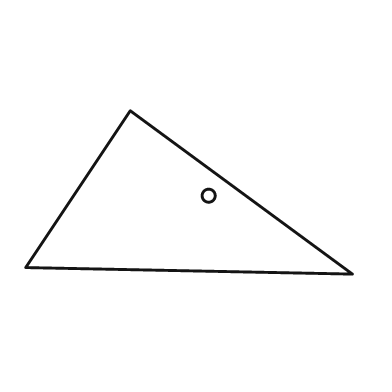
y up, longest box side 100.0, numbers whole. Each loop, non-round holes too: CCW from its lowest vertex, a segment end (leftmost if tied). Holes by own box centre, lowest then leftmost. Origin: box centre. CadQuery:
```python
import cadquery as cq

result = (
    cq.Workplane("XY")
    .moveTo(50.0, -25.0)
    .lineTo(-18.0, 25.0)
    .lineTo(-50.0, -23.0)
    .close()
    .moveTo(6.0, -1.0)
    .circle(2.0)
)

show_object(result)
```